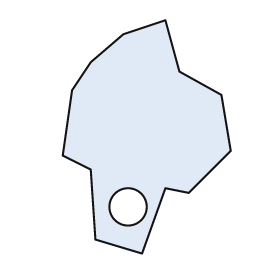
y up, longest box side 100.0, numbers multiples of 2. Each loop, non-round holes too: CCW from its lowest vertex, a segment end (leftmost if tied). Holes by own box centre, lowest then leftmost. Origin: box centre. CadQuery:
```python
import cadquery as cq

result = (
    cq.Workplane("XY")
    .moveTo(-2.0, -50.0)
    .lineTo(8.0, -22.0)
    .lineTo(18.0, -24.0)
    .lineTo(36.0, -6.0)
    .lineTo(32.0, 18.0)
    .lineTo(14.0, 28.0)
    .lineTo(8.0, 50.0)
    .lineTo(-10.0, 44.0)
    .lineTo(-24.0, 32.0)
    .lineTo(-32.0, 20.0)
    .lineTo(-36.0, -8.0)
    .lineTo(-24.0, -14.0)
    .lineTo(-22.0, -44.0)
    .close()
    .moveTo(-8.0, -30.0)
    .circle(8.0)
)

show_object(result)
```